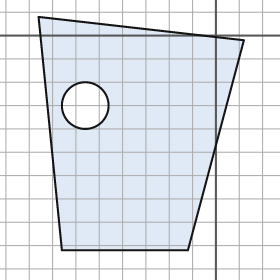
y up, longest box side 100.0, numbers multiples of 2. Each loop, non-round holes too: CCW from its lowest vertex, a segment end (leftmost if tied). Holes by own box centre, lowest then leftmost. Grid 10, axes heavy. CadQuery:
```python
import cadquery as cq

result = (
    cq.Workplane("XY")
    .moveTo(-66.0, -92.0)
    .lineTo(-12.0, -92.0)
    .lineTo(12.0, -2.0)
    .lineTo(-76.0, 8.0)
    .close()
    .moveTo(-56.0, -30.0)
    .circle(10.0)
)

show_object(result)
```